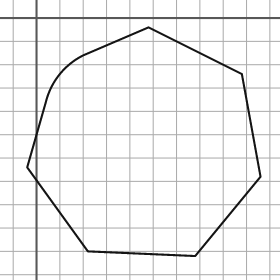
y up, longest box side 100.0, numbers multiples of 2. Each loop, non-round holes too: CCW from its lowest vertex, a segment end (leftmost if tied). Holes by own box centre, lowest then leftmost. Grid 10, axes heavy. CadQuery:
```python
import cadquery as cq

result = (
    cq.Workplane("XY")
    .moveTo(68.0, -102.0)
    .lineTo(96.0, -68.0)
    .lineTo(88.0, -24.0)
    .lineTo(48.0, -4.0)
    .lineTo(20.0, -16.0)
    .threePointArc((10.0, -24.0), (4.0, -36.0))
    .lineTo(-4.0, -64.0)
    .lineTo(22.0, -100.0)
    .close()
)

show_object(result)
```